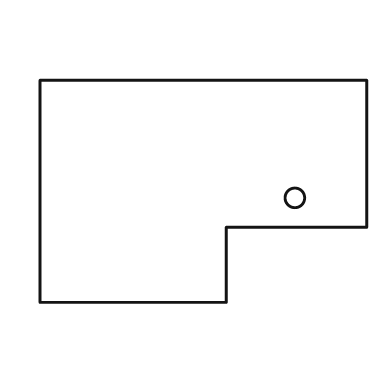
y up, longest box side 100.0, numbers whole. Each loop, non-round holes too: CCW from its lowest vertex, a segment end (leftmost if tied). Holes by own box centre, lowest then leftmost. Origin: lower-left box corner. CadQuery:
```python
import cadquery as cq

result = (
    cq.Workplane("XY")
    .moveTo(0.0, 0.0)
    .lineTo(57.0, 0.0)
    .lineTo(57.0, 23.0)
    .lineTo(100.0, 23.0)
    .lineTo(100.0, 68.0)
    .lineTo(0.0, 68.0)
    .close()
    .moveTo(78.0, 32.0)
    .circle(3.0)
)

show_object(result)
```